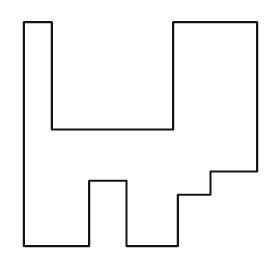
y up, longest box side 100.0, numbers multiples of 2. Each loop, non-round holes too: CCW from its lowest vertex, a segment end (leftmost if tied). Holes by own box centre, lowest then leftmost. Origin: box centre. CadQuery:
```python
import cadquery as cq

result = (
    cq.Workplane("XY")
    .moveTo(-50.0, -48.0)
    .lineTo(-22.0, -48.0)
    .lineTo(-22.0, -20.0)
    .lineTo(-6.0, -20.0)
    .lineTo(-6.0, -48.0)
    .lineTo(16.0, -48.0)
    .lineTo(16.0, -26.0)
    .lineTo(30.0, -26.0)
    .lineTo(30.0, -16.0)
    .lineTo(50.0, -16.0)
    .lineTo(50.0, 48.0)
    .lineTo(14.0, 48.0)
    .lineTo(14.0, 2.0)
    .lineTo(-38.0, 2.0)
    .lineTo(-38.0, 48.0)
    .lineTo(-50.0, 48.0)
    .close()
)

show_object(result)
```